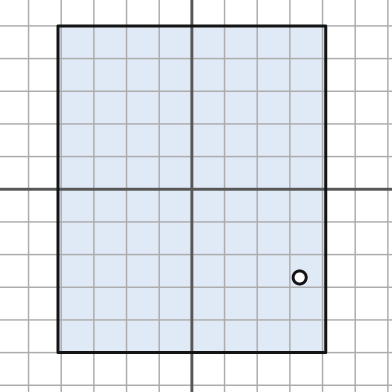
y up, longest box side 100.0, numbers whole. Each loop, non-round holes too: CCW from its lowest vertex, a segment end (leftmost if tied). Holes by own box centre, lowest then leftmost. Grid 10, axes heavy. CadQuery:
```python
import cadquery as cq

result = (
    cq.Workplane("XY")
    .moveTo(-41.0, -50.0)
    .lineTo(41.0, -50.0)
    .lineTo(41.0, 50.0)
    .lineTo(-41.0, 50.0)
    .close()
    .moveTo(33.0, -27.0)
    .circle(2.0)
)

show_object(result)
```